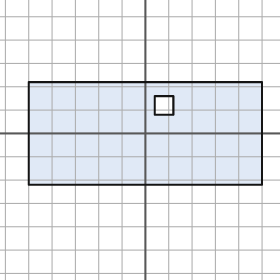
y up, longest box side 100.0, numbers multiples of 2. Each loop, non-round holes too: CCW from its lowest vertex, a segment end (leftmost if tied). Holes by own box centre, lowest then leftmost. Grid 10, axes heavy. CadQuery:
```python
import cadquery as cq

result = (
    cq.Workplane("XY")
    .moveTo(-50.0, -22.0)
    .lineTo(50.0, -22.0)
    .lineTo(50.0, 22.0)
    .lineTo(-50.0, 22.0)
    .close()
    .moveTo(4.0, 8.0)
    .lineTo(12.0, 8.0)
    .lineTo(12.0, 16.0)
    .lineTo(4.0, 16.0)
    .close()
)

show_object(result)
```